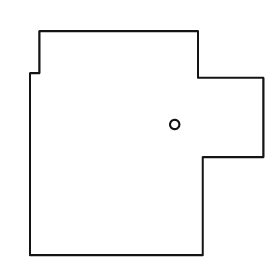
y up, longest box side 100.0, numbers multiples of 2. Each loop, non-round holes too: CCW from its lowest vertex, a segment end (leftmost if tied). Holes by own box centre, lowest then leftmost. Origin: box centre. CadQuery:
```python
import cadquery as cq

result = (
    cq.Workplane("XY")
    .moveTo(-50.0, -48.0)
    .lineTo(24.0, -48.0)
    .lineTo(24.0, -6.0)
    .lineTo(50.0, -6.0)
    .lineTo(50.0, 28.0)
    .lineTo(22.0, 28.0)
    .lineTo(22.0, 48.0)
    .lineTo(-46.0, 48.0)
    .lineTo(-46.0, 30.0)
    .lineTo(-50.0, 30.0)
    .close()
    .moveTo(12.0, 8.0)
    .circle(2.0)
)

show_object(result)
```